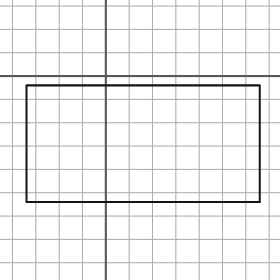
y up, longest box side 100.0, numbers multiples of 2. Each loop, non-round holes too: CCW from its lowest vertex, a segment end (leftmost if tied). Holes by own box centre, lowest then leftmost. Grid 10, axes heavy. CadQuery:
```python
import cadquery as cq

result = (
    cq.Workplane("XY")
    .moveTo(-34.0, -54.0)
    .lineTo(66.0, -54.0)
    .lineTo(66.0, -4.0)
    .lineTo(-34.0, -4.0)
    .close()
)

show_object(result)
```